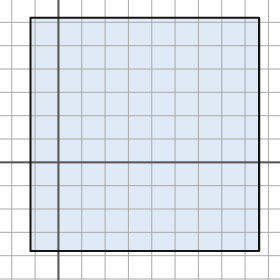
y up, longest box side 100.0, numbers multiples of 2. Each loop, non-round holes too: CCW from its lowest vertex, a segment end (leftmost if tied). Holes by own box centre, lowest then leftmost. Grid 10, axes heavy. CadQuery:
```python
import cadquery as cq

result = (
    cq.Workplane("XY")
    .moveTo(-12.0, -38.0)
    .lineTo(86.0, -38.0)
    .lineTo(86.0, 62.0)
    .lineTo(-12.0, 62.0)
    .close()
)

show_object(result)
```